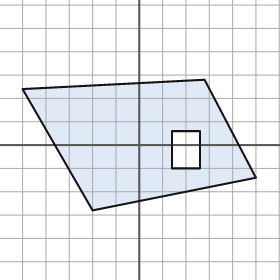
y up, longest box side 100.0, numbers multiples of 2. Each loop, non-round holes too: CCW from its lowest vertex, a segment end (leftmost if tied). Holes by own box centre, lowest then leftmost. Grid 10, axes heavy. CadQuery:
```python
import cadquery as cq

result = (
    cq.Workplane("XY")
    .moveTo(-20.0, -28.0)
    .lineTo(50.0, -14.0)
    .lineTo(28.0, 28.0)
    .lineTo(-50.0, 24.0)
    .close()
    .moveTo(14.0, -10.0)
    .lineTo(26.0, -10.0)
    .lineTo(26.0, 6.0)
    .lineTo(14.0, 6.0)
    .close()
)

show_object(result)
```